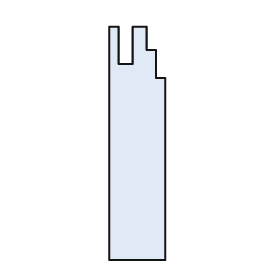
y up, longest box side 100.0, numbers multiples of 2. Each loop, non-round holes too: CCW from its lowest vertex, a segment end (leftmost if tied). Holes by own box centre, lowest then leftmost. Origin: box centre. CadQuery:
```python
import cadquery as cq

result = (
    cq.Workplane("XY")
    .moveTo(-12.0, -50.0)
    .lineTo(12.0, -50.0)
    .lineTo(12.0, 28.0)
    .lineTo(8.0, 28.0)
    .lineTo(8.0, 40.0)
    .lineTo(4.0, 40.0)
    .lineTo(4.0, 50.0)
    .lineTo(-2.0, 50.0)
    .lineTo(-2.0, 34.0)
    .lineTo(-8.0, 34.0)
    .lineTo(-8.0, 50.0)
    .lineTo(-12.0, 50.0)
    .close()
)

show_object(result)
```